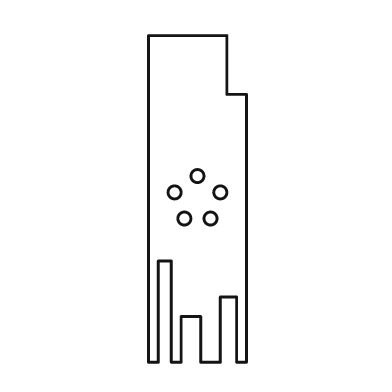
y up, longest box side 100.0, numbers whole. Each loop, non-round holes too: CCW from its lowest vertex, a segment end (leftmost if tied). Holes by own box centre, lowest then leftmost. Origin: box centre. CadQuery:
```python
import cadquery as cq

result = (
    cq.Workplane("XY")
    .moveTo(-15.0, -50.0)
    .lineTo(-12.0, -50.0)
    .lineTo(-12.0, -19.0)
    .lineTo(-8.0, -19.0)
    .lineTo(-8.0, -50.0)
    .lineTo(-5.0, -50.0)
    .lineTo(-5.0, -36.0)
    .lineTo(1.0, -36.0)
    .lineTo(1.0, -50.0)
    .lineTo(7.0, -50.0)
    .lineTo(7.0, -30.0)
    .lineTo(12.0, -30.0)
    .lineTo(12.0, -50.0)
    .lineTo(15.0, -50.0)
    .lineTo(15.0, 32.0)
    .lineTo(9.0, 32.0)
    .lineTo(9.0, 50.0)
    .lineTo(-15.0, 50.0)
    .close()
    .moveTo(-4.0, -6.0)
    .circle(2.0)
    .moveTo(4.0, -6.0)
    .circle(2.0)
    .moveTo(-7.0, 2.0)
    .circle(2.0)
    .moveTo(7.0, 2.0)
    .circle(2.0)
    .moveTo(0.0, 7.0)
    .circle(2.0)
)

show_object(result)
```